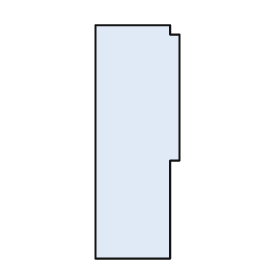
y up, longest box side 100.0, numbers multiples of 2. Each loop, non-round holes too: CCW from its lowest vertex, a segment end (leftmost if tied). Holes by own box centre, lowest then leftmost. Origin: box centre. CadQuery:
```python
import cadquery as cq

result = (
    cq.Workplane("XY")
    .moveTo(-18.0, -50.0)
    .lineTo(14.0, -50.0)
    .lineTo(14.0, -8.0)
    .lineTo(18.0, -8.0)
    .lineTo(18.0, 46.0)
    .lineTo(14.0, 46.0)
    .lineTo(14.0, 50.0)
    .lineTo(-18.0, 50.0)
    .close()
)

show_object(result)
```